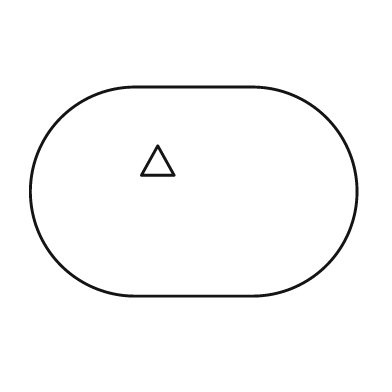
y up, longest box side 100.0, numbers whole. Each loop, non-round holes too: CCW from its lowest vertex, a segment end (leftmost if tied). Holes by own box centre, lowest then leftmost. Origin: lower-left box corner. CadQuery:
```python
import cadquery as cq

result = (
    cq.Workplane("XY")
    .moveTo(32.0, 0.0)
    .lineTo(68.0, 0.0)
    .threePointArc((100.0, 32.0), (68.0, 64.0))
    .lineTo(32.0, 64.0)
    .threePointArc((0.0, 32.0), (32.0, 0.0))
    .close()
    .moveTo(34.0, 37.0)
    .lineTo(44.0, 37.0)
    .lineTo(39.0, 46.0)
    .close()
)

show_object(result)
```